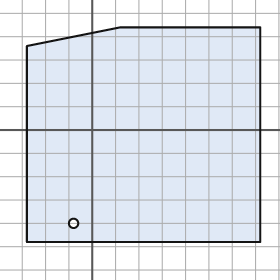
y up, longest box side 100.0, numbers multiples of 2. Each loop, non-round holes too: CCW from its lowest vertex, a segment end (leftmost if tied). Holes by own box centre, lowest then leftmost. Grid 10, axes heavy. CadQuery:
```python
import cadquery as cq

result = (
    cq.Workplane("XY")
    .moveTo(-28.0, -48.0)
    .lineTo(72.0, -48.0)
    .lineTo(72.0, 44.0)
    .lineTo(12.0, 44.0)
    .lineTo(-28.0, 36.0)
    .close()
    .moveTo(-8.0, -40.0)
    .circle(2.0)
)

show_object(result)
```